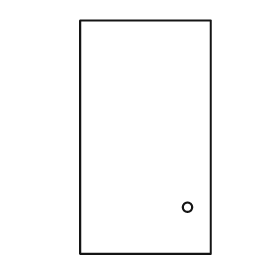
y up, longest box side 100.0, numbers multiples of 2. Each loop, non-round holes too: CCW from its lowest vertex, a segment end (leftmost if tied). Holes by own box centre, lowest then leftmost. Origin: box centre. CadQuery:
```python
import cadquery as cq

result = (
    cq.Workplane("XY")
    .moveTo(-28.0, -50.0)
    .lineTo(28.0, -50.0)
    .lineTo(28.0, 50.0)
    .lineTo(-28.0, 50.0)
    .close()
    .moveTo(18.0, -30.0)
    .circle(2.0)
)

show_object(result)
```